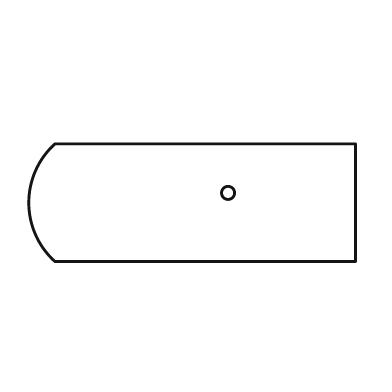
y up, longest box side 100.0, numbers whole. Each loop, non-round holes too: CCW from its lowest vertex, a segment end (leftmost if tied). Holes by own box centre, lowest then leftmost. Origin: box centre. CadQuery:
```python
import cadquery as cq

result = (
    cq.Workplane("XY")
    .moveTo(-42.0, -18.0)
    .lineTo(50.0, -18.0)
    .lineTo(50.0, 18.0)
    .lineTo(-42.0, 18.0)
    .threePointArc((-50.0, 0.0), (-42.0, -18.0))
    .close()
    .moveTo(11.0, 3.0)
    .circle(2.0)
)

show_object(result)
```